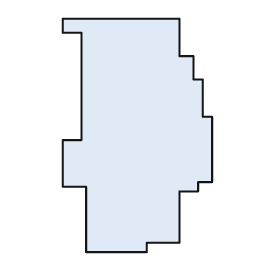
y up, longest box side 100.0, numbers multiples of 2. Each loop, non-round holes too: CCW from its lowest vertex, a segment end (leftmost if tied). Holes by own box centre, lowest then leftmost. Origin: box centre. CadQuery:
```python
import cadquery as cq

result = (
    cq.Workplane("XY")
    .moveTo(-22.0, -50.0)
    .lineTo(4.0, -50.0)
    .lineTo(4.0, -46.0)
    .lineTo(18.0, -46.0)
    .lineTo(18.0, -24.0)
    .lineTo(26.0, -24.0)
    .lineTo(26.0, -20.0)
    .lineTo(32.0, -20.0)
    .lineTo(32.0, 8.0)
    .lineTo(28.0, 8.0)
    .lineTo(28.0, 24.0)
    .lineTo(24.0, 24.0)
    .lineTo(24.0, 34.0)
    .lineTo(18.0, 34.0)
    .lineTo(18.0, 50.0)
    .lineTo(-32.0, 50.0)
    .lineTo(-32.0, 44.0)
    .lineTo(-24.0, 44.0)
    .lineTo(-24.0, -2.0)
    .lineTo(-32.0, -2.0)
    .lineTo(-32.0, -22.0)
    .lineTo(-22.0, -22.0)
    .close()
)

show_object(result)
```